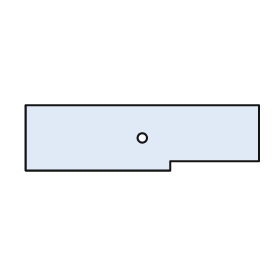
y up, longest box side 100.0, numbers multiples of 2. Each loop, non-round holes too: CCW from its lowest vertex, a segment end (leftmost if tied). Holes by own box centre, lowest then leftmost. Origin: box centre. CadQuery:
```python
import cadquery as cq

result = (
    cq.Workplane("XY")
    .moveTo(-50.0, -14.0)
    .lineTo(12.0, -14.0)
    .lineTo(12.0, -10.0)
    .lineTo(50.0, -10.0)
    .lineTo(50.0, 14.0)
    .lineTo(-50.0, 14.0)
    .close()
    .moveTo(0.0, 0.0)
    .circle(2.0)
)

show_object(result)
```